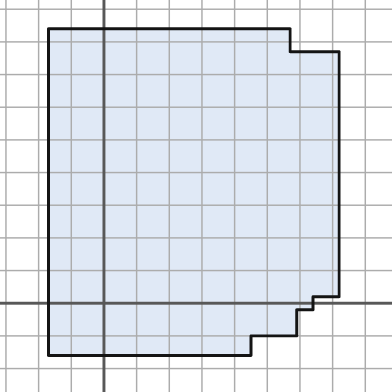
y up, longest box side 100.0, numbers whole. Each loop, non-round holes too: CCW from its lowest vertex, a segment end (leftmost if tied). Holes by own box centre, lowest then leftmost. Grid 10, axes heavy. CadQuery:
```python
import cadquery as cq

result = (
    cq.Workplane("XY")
    .moveTo(-17.0, -16.0)
    .lineTo(45.0, -16.0)
    .lineTo(45.0, -10.0)
    .lineTo(59.0, -10.0)
    .lineTo(59.0, -2.0)
    .lineTo(64.0, -2.0)
    .lineTo(64.0, 2.0)
    .lineTo(72.0, 2.0)
    .lineTo(72.0, 77.0)
    .lineTo(57.0, 77.0)
    .lineTo(57.0, 84.0)
    .lineTo(-17.0, 84.0)
    .close()
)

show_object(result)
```